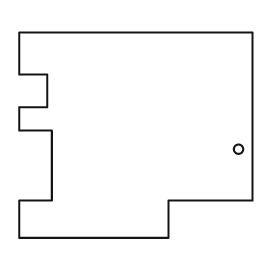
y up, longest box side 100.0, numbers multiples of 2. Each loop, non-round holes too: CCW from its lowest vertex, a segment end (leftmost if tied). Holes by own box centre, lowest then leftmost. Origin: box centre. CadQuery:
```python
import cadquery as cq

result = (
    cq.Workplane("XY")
    .moveTo(-50.0, -44.0)
    .lineTo(14.0, -44.0)
    .lineTo(14.0, -28.0)
    .lineTo(50.0, -28.0)
    .lineTo(50.0, 44.0)
    .lineTo(-50.0, 44.0)
    .lineTo(-50.0, 26.0)
    .lineTo(-38.0, 26.0)
    .lineTo(-38.0, 12.0)
    .lineTo(-50.0, 12.0)
    .lineTo(-50.0, 2.0)
    .lineTo(-36.0, 2.0)
    .lineTo(-36.0, -28.0)
    .lineTo(-50.0, -28.0)
    .close()
    .moveTo(44.0, -6.0)
    .circle(2.0)
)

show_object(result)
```